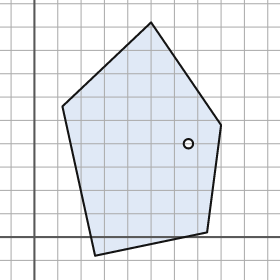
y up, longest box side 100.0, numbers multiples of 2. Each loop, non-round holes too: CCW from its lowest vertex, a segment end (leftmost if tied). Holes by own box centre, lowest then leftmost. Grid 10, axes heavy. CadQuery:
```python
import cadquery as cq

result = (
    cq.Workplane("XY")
    .moveTo(26.0, -8.0)
    .lineTo(74.0, 2.0)
    .lineTo(80.0, 48.0)
    .lineTo(50.0, 92.0)
    .lineTo(12.0, 56.0)
    .close()
    .moveTo(66.0, 40.0)
    .circle(2.0)
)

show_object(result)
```